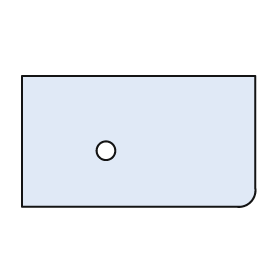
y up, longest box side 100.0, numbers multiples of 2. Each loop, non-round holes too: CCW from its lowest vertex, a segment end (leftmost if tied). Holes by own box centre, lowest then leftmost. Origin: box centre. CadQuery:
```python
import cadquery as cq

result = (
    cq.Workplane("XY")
    .moveTo(-50.0, -28.0)
    .lineTo(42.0, -28.0)
    .threePointArc((48.0, -26.0), (50.0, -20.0))
    .lineTo(50.0, 28.0)
    .lineTo(-50.0, 28.0)
    .close()
    .moveTo(-14.0, -4.0)
    .circle(4.0)
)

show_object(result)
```